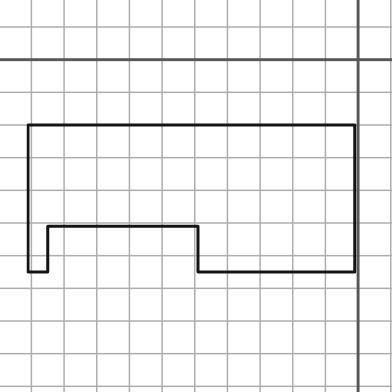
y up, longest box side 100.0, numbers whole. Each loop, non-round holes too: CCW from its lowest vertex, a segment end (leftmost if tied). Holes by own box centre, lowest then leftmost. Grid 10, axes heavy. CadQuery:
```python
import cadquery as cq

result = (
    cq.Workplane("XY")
    .moveTo(-101.0, -65.0)
    .lineTo(-95.0, -65.0)
    .lineTo(-95.0, -51.0)
    .lineTo(-49.0, -51.0)
    .lineTo(-49.0, -65.0)
    .lineTo(-1.0, -65.0)
    .lineTo(-1.0, -20.0)
    .lineTo(-101.0, -20.0)
    .close()
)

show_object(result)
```